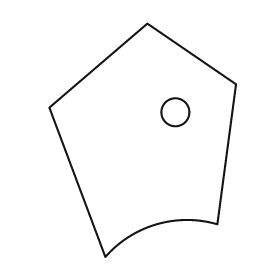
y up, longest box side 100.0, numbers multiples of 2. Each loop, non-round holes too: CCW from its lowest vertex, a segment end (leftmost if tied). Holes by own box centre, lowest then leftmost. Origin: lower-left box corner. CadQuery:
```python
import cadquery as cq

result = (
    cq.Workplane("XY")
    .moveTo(24.0, 0.0)
    .threePointArc((46.0, 14.0), (72.0, 14.0))
    .lineTo(80.0, 74.0)
    .lineTo(42.0, 100.0)
    .lineTo(0.0, 64.0)
    .close()
    .moveTo(54.0, 62.0)
    .circle(6.0)
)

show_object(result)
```